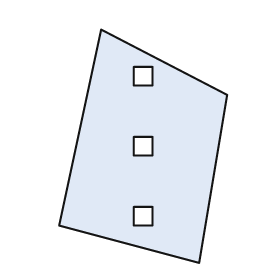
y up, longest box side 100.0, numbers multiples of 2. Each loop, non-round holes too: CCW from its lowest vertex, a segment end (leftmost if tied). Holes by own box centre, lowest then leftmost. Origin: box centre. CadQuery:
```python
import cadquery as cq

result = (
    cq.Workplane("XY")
    .moveTo(24.0, -50.0)
    .lineTo(36.0, 22.0)
    .lineTo(-18.0, 50.0)
    .lineTo(-36.0, -34.0)
    .close()
    .moveTo(-4.0, -34.0)
    .lineTo(4.0, -34.0)
    .lineTo(4.0, -26.0)
    .lineTo(-4.0, -26.0)
    .close()
    .moveTo(-4.0, -4.0)
    .lineTo(4.0, -4.0)
    .lineTo(4.0, 4.0)
    .lineTo(-4.0, 4.0)
    .close()
    .moveTo(-4.0, 26.0)
    .lineTo(4.0, 26.0)
    .lineTo(4.0, 34.0)
    .lineTo(-4.0, 34.0)
    .close()
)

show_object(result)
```